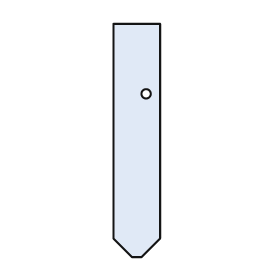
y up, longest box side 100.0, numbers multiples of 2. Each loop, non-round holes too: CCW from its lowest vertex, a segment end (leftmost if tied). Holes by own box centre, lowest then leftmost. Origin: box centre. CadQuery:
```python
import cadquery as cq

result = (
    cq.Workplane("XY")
    .moveTo(-2.0, -50.0)
    .lineTo(2.0, -50.0)
    .lineTo(10.0, -42.0)
    .lineTo(10.0, 50.0)
    .lineTo(-10.0, 50.0)
    .lineTo(-10.0, -42.0)
    .close()
    .moveTo(4.0, 20.0)
    .circle(2.0)
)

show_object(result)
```